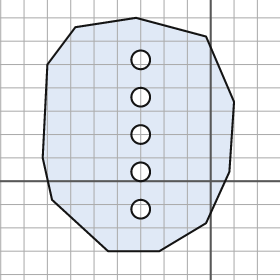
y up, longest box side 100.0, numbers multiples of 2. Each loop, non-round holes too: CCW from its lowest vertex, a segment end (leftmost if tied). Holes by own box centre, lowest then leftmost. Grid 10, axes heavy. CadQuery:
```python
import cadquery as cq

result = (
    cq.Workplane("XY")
    .moveTo(-44.0, -30.0)
    .lineTo(-22.0, -30.0)
    .lineTo(-2.0, -18.0)
    .lineTo(8.0, 4.0)
    .lineTo(10.0, 34.0)
    .lineTo(-2.0, 62.0)
    .lineTo(-32.0, 70.0)
    .lineTo(-58.0, 66.0)
    .lineTo(-70.0, 50.0)
    .lineTo(-72.0, 10.0)
    .lineTo(-68.0, -8.0)
    .close()
    .moveTo(-30.0, -12.0)
    .circle(4.0)
    .moveTo(-30.0, 4.0)
    .circle(4.0)
    .moveTo(-30.0, 20.0)
    .circle(4.0)
    .moveTo(-30.0, 36.0)
    .circle(4.0)
    .moveTo(-30.0, 52.0)
    .circle(4.0)
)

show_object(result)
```